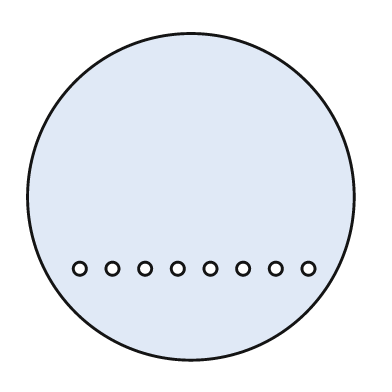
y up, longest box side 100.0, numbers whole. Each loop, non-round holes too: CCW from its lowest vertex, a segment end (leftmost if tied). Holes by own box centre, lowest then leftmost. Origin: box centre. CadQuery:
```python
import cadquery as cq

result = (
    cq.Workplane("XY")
    .moveTo(0.0, 0.0)
    .circle(50.0)
    .moveTo(-34.0, -22.0)
    .circle(2.0)
    .moveTo(-24.0, -22.0)
    .circle(2.0)
    .moveTo(-14.0, -22.0)
    .circle(2.0)
    .moveTo(-4.0, -22.0)
    .circle(2.0)
    .moveTo(6.0, -22.0)
    .circle(2.0)
    .moveTo(16.0, -22.0)
    .circle(2.0)
    .moveTo(26.0, -22.0)
    .circle(2.0)
    .moveTo(36.0, -22.0)
    .circle(2.0)
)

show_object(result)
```